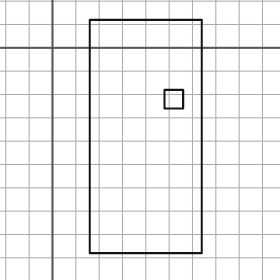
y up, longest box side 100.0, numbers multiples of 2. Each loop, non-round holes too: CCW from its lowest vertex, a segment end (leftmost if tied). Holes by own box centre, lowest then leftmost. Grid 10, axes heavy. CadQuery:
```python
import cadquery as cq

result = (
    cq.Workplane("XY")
    .moveTo(16.0, -88.0)
    .lineTo(64.0, -88.0)
    .lineTo(64.0, 12.0)
    .lineTo(16.0, 12.0)
    .close()
    .moveTo(48.0, -26.0)
    .lineTo(56.0, -26.0)
    .lineTo(56.0, -18.0)
    .lineTo(48.0, -18.0)
    .close()
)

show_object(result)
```